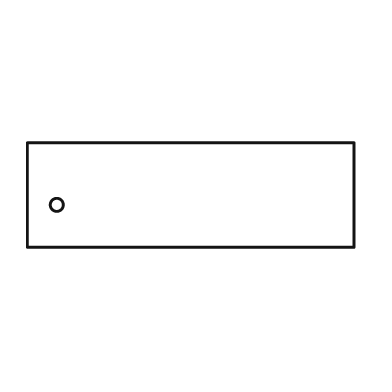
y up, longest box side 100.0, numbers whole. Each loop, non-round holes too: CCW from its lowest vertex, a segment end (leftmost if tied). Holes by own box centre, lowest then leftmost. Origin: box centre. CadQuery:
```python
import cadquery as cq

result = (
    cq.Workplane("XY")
    .moveTo(-50.0, -16.0)
    .lineTo(50.0, -16.0)
    .lineTo(50.0, 16.0)
    .lineTo(-50.0, 16.0)
    .close()
    .moveTo(-41.0, -3.0)
    .circle(2.0)
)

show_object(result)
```